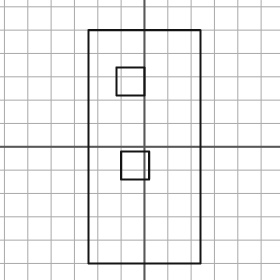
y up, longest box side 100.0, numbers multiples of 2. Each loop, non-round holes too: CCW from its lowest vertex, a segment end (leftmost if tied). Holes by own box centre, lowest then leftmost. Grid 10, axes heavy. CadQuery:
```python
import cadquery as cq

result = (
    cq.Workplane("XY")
    .moveTo(-24.0, -50.0)
    .lineTo(24.0, -50.0)
    .lineTo(24.0, 50.0)
    .lineTo(-24.0, 50.0)
    .close()
    .moveTo(-10.0, -14.0)
    .lineTo(2.0, -14.0)
    .lineTo(2.0, -2.0)
    .lineTo(-10.0, -2.0)
    .close()
    .moveTo(-12.0, 22.0)
    .lineTo(0.0, 22.0)
    .lineTo(0.0, 34.0)
    .lineTo(-12.0, 34.0)
    .close()
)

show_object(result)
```